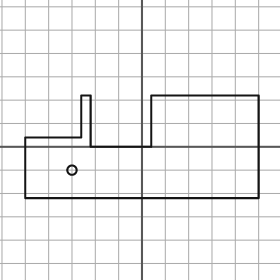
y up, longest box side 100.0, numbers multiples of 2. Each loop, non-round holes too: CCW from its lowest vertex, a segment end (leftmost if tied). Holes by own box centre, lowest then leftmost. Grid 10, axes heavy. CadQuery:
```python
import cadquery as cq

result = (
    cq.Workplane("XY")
    .moveTo(-50.0, -22.0)
    .lineTo(50.0, -22.0)
    .lineTo(50.0, 22.0)
    .lineTo(4.0, 22.0)
    .lineTo(4.0, 0.0)
    .lineTo(-22.0, 0.0)
    .lineTo(-22.0, 22.0)
    .lineTo(-26.0, 22.0)
    .lineTo(-26.0, 4.0)
    .lineTo(-50.0, 4.0)
    .close()
    .moveTo(-30.0, -10.0)
    .circle(2.0)
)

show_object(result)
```